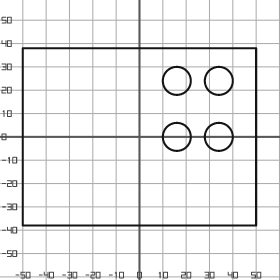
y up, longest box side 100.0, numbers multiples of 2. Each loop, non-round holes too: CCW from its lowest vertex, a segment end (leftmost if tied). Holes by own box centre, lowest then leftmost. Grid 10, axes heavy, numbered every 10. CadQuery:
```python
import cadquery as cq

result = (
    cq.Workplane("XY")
    .moveTo(-50.0, -38.0)
    .lineTo(50.0, -38.0)
    .lineTo(50.0, 38.0)
    .lineTo(-50.0, 38.0)
    .close()
    .moveTo(16.0, 0.0)
    .circle(6.0)
    .moveTo(34.0, 0.0)
    .circle(6.0)
    .moveTo(16.0, 24.0)
    .circle(6.0)
    .moveTo(34.0, 24.0)
    .circle(6.0)
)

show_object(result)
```